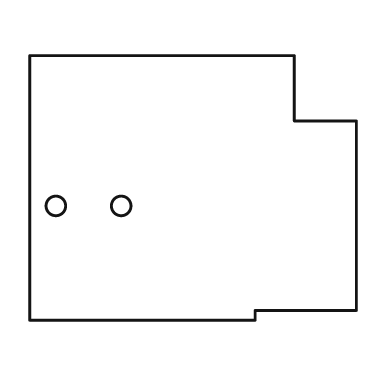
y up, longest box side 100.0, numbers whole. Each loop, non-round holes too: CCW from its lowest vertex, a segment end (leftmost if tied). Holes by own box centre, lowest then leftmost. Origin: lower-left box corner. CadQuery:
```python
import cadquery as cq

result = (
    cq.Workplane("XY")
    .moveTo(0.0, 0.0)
    .lineTo(69.0, 0.0)
    .lineTo(69.0, 3.0)
    .lineTo(100.0, 3.0)
    .lineTo(100.0, 61.0)
    .lineTo(81.0, 61.0)
    .lineTo(81.0, 81.0)
    .lineTo(0.0, 81.0)
    .close()
    .moveTo(8.0, 35.0)
    .circle(3.0)
    .moveTo(28.0, 35.0)
    .circle(3.0)
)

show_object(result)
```